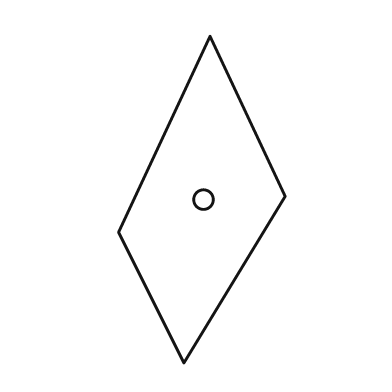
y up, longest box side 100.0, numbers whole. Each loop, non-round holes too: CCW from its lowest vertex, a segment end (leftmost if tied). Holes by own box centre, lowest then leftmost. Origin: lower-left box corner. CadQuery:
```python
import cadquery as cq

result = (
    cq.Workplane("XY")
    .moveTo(20.0, 0.0)
    .lineTo(51.0, 51.0)
    .lineTo(28.0, 100.0)
    .lineTo(0.0, 40.0)
    .close()
    .moveTo(26.0, 50.0)
    .circle(3.0)
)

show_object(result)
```